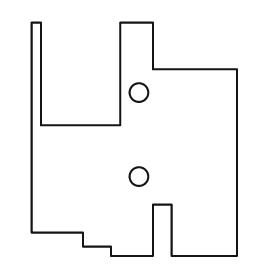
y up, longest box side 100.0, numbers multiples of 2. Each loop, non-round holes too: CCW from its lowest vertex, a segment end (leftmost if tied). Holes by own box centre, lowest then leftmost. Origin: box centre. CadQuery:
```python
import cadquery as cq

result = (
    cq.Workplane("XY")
    .moveTo(-10.0, -50.0)
    .lineTo(8.0, -50.0)
    .lineTo(8.0, -28.0)
    .lineTo(16.0, -28.0)
    .lineTo(16.0, -50.0)
    .lineTo(44.0, -50.0)
    .lineTo(44.0, 30.0)
    .lineTo(8.0, 30.0)
    .lineTo(8.0, 50.0)
    .lineTo(-6.0, 50.0)
    .lineTo(-6.0, 6.0)
    .lineTo(-40.0, 6.0)
    .lineTo(-40.0, 50.0)
    .lineTo(-44.0, 50.0)
    .lineTo(-44.0, -40.0)
    .lineTo(-22.0, -40.0)
    .lineTo(-22.0, -46.0)
    .lineTo(-10.0, -46.0)
    .close()
    .moveTo(2.0, -16.0)
    .circle(4.0)
    .moveTo(2.0, 20.0)
    .circle(4.0)
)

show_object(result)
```